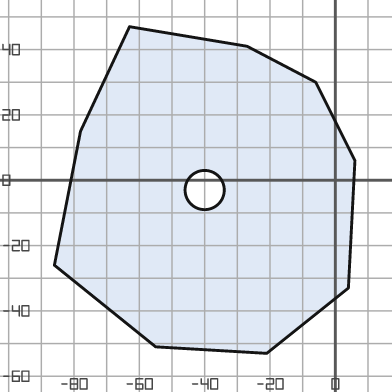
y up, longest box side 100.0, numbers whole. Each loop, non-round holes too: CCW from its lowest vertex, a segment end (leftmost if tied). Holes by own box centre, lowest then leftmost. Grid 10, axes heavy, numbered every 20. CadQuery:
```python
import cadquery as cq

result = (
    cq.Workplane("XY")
    .moveTo(-21.0, -53.0)
    .lineTo(4.0, -33.0)
    .lineTo(6.0, 6.0)
    .lineTo(-6.0, 30.0)
    .lineTo(-27.0, 41.0)
    .lineTo(-63.0, 47.0)
    .lineTo(-78.0, 15.0)
    .lineTo(-86.0, -26.0)
    .lineTo(-55.0, -51.0)
    .close()
    .moveTo(-40.0, -3.0)
    .circle(6.0)
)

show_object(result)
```